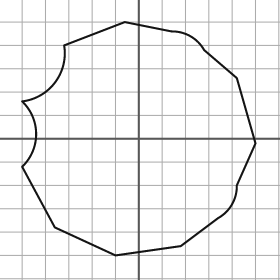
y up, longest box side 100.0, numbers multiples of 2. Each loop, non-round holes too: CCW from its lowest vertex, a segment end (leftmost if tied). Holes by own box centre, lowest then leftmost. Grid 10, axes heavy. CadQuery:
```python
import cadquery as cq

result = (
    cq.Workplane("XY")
    .moveTo(-10.0, -50.0)
    .lineTo(18.0, -46.0)
    .lineTo(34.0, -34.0)
    .threePointArc((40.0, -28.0), (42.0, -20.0))
    .lineTo(50.0, -2.0)
    .lineTo(42.0, 26.0)
    .lineTo(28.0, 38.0)
    .threePointArc((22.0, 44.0), (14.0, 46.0))
    .lineTo(-6.0, 50.0)
    .lineTo(-32.0, 40.0)
    .threePointArc((-36.0, 24.0), (-50.0, 16.0))
    .threePointArc((-44.0, 2.0), (-50.0, -12.0))
    .lineTo(-36.0, -38.0)
    .close()
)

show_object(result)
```